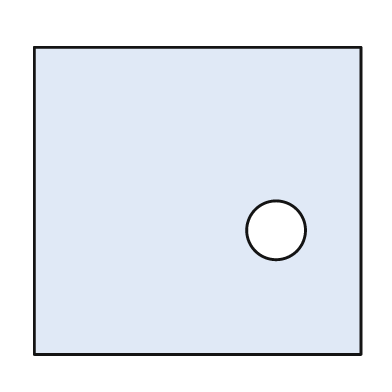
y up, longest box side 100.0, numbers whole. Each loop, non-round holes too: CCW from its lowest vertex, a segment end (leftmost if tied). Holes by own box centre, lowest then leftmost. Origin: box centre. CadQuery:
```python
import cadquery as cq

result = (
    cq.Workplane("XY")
    .moveTo(-50.0, -47.0)
    .lineTo(50.0, -47.0)
    .lineTo(50.0, 47.0)
    .lineTo(-50.0, 47.0)
    .close()
    .moveTo(24.0, -9.0)
    .circle(9.0)
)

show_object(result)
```